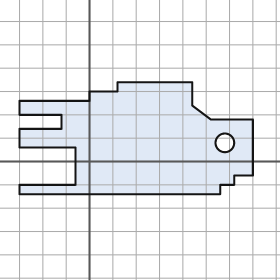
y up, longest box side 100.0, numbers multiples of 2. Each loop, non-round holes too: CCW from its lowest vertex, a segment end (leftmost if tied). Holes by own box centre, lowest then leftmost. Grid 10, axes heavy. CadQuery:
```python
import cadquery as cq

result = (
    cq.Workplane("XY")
    .moveTo(-30.0, -14.0)
    .lineTo(56.0, -14.0)
    .lineTo(56.0, -10.0)
    .lineTo(62.0, -10.0)
    .lineTo(62.0, -6.0)
    .lineTo(70.0, -6.0)
    .lineTo(70.0, 18.0)
    .lineTo(52.0, 18.0)
    .lineTo(44.0, 24.0)
    .lineTo(44.0, 34.0)
    .lineTo(12.0, 34.0)
    .lineTo(12.0, 30.0)
    .lineTo(0.0, 30.0)
    .lineTo(0.0, 26.0)
    .lineTo(-30.0, 26.0)
    .lineTo(-30.0, 20.0)
    .lineTo(-12.0, 20.0)
    .lineTo(-12.0, 14.0)
    .lineTo(-30.0, 14.0)
    .lineTo(-30.0, 6.0)
    .lineTo(-6.0, 6.0)
    .lineTo(-6.0, -10.0)
    .lineTo(-30.0, -10.0)
    .close()
    .moveTo(58.0, 8.0)
    .circle(4.0)
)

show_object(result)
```